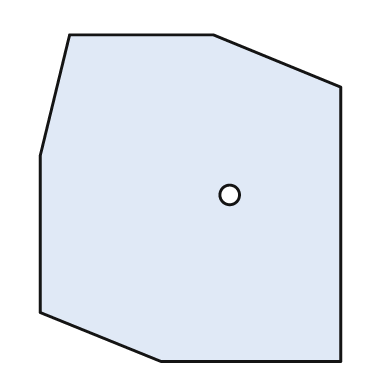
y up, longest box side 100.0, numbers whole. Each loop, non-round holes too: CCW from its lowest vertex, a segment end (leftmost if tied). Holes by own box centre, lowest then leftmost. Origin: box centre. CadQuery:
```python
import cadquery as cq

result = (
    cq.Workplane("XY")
    .moveTo(-9.0, -50.0)
    .lineTo(46.0, -50.0)
    .lineTo(46.0, 34.0)
    .lineTo(7.0, 50.0)
    .lineTo(-37.0, 50.0)
    .lineTo(-46.0, 13.0)
    .lineTo(-46.0, -35.0)
    .close()
    .moveTo(12.0, 1.0)
    .circle(3.0)
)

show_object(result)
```